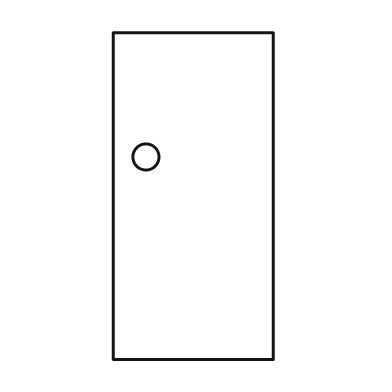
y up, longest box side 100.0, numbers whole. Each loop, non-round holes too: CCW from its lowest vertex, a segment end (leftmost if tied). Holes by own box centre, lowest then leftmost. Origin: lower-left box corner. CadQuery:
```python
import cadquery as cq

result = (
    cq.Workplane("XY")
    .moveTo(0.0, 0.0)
    .lineTo(49.0, 0.0)
    .lineTo(49.0, 100.0)
    .lineTo(0.0, 100.0)
    .close()
    .moveTo(10.0, 62.0)
    .circle(4.0)
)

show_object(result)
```